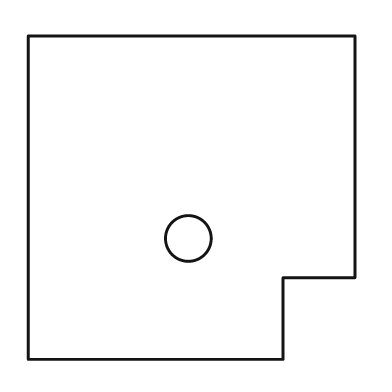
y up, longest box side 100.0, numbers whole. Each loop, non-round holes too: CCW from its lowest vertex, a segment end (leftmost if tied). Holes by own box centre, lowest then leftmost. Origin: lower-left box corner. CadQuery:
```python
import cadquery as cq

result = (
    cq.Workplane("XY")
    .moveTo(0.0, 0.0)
    .lineTo(78.0, 0.0)
    .lineTo(78.0, 25.0)
    .lineTo(100.0, 25.0)
    .lineTo(100.0, 99.0)
    .lineTo(0.0, 99.0)
    .close()
    .moveTo(49.0, 37.0)
    .circle(7.0)
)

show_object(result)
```